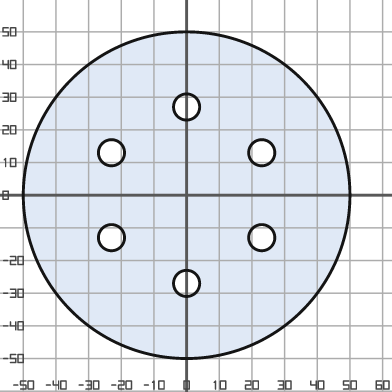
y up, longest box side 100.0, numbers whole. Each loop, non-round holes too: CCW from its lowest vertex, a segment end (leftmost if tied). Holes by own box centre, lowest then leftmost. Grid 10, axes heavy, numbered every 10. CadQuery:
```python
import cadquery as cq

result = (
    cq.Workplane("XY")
    .moveTo(0.0, 0.0)
    .circle(50.0)
    .moveTo(0.0, -27.0)
    .circle(4.0)
    .moveTo(-23.0, -13.0)
    .circle(4.0)
    .moveTo(23.0, -13.0)
    .circle(4.0)
    .moveTo(-23.0, 13.0)
    .circle(4.0)
    .moveTo(23.0, 13.0)
    .circle(4.0)
    .moveTo(0.0, 27.0)
    .circle(4.0)
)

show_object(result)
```